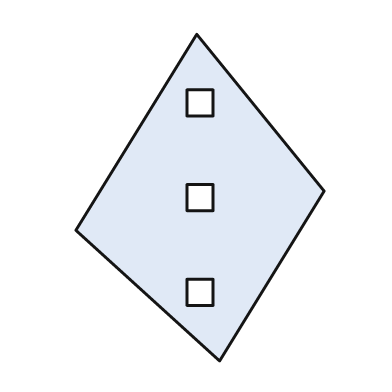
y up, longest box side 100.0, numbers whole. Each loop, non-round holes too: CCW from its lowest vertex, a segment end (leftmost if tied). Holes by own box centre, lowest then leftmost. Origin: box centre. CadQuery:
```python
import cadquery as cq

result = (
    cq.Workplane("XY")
    .moveTo(6.0, -50.0)
    .lineTo(38.0, 2.0)
    .lineTo(-1.0, 50.0)
    .lineTo(-38.0, -10.0)
    .close()
    .moveTo(-4.0, -33.0)
    .lineTo(4.0, -33.0)
    .lineTo(4.0, -25.0)
    .lineTo(-4.0, -25.0)
    .close()
    .moveTo(-4.0, -4.0)
    .lineTo(4.0, -4.0)
    .lineTo(4.0, 4.0)
    .lineTo(-4.0, 4.0)
    .close()
    .moveTo(-4.0, 25.0)
    .lineTo(4.0, 25.0)
    .lineTo(4.0, 33.0)
    .lineTo(-4.0, 33.0)
    .close()
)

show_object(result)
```